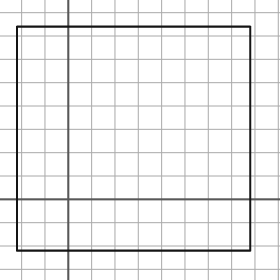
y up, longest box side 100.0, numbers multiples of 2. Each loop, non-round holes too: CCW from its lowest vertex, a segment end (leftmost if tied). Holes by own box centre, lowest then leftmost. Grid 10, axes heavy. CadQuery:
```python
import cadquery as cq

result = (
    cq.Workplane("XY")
    .moveTo(-22.0, -22.0)
    .lineTo(78.0, -22.0)
    .lineTo(78.0, 74.0)
    .lineTo(-22.0, 74.0)
    .close()
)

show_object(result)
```